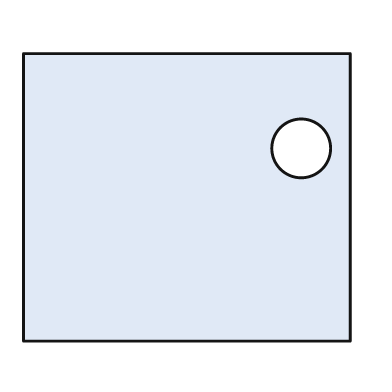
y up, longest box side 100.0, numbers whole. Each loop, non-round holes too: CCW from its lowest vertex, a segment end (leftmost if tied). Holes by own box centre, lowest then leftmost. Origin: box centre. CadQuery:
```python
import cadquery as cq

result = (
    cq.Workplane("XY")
    .moveTo(-50.0, -44.0)
    .lineTo(50.0, -44.0)
    .lineTo(50.0, 44.0)
    .lineTo(-50.0, 44.0)
    .close()
    .moveTo(35.0, 15.0)
    .circle(9.0)
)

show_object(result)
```